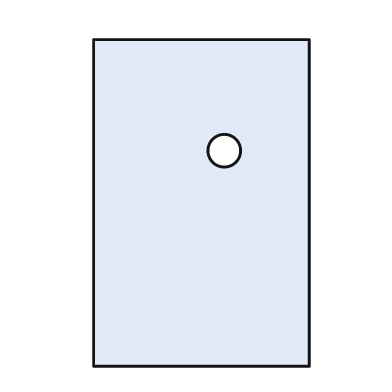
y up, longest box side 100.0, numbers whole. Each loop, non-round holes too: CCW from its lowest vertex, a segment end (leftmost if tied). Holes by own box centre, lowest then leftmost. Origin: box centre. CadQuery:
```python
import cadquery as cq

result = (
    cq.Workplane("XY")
    .moveTo(-33.0, -50.0)
    .lineTo(33.0, -50.0)
    .lineTo(33.0, 50.0)
    .lineTo(-33.0, 50.0)
    .close()
    .moveTo(7.0, 16.0)
    .circle(5.0)
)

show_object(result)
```